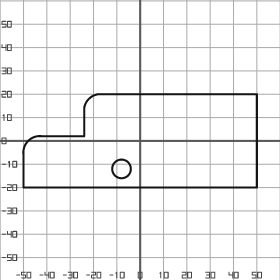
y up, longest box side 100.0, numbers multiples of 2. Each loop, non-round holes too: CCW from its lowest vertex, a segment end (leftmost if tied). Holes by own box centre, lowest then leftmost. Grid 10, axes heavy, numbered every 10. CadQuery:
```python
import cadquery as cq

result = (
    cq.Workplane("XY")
    .moveTo(-50.0, -20.0)
    .lineTo(50.0, -20.0)
    .lineTo(50.0, 20.0)
    .lineTo(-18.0, 20.0)
    .threePointArc((-22.0, 18.0), (-24.0, 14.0))
    .lineTo(-24.0, 2.0)
    .lineTo(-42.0, 2.0)
    .threePointArc((-48.0, 0.0), (-50.0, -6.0))
    .close()
    .moveTo(-8.0, -12.0)
    .circle(4.0)
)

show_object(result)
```